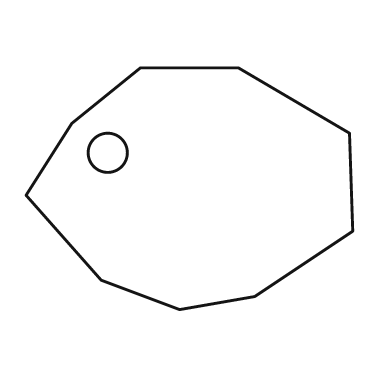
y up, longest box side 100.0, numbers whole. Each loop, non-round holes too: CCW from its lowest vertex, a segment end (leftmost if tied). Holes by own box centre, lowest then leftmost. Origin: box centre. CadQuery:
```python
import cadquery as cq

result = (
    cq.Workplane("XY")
    .moveTo(-3.0, -37.0)
    .lineTo(20.0, -33.0)
    .lineTo(50.0, -13.0)
    .lineTo(49.0, 17.0)
    .lineTo(15.0, 37.0)
    .lineTo(-15.0, 37.0)
    .lineTo(-36.0, 20.0)
    .lineTo(-50.0, -2.0)
    .lineTo(-27.0, -28.0)
    .close()
    .moveTo(-25.0, 11.0)
    .circle(6.0)
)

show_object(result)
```